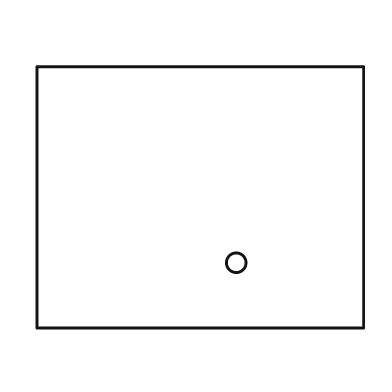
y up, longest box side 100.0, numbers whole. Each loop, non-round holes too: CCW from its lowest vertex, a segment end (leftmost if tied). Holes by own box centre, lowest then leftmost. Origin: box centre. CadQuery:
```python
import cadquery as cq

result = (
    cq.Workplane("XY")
    .moveTo(-50.0, -40.0)
    .lineTo(50.0, -40.0)
    .lineTo(50.0, 40.0)
    .lineTo(-50.0, 40.0)
    .close()
    .moveTo(11.0, -20.0)
    .circle(3.0)
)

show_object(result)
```